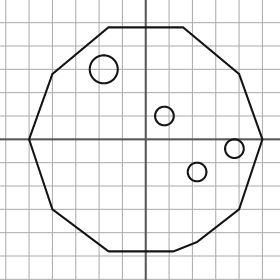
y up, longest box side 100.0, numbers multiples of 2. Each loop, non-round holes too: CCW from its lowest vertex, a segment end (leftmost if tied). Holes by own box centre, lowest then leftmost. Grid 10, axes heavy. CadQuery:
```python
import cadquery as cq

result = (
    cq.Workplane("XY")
    .moveTo(-16.0, -48.0)
    .lineTo(12.0, -48.0)
    .lineTo(22.0, -44.0)
    .lineTo(40.0, -30.0)
    .lineTo(50.0, 0.0)
    .lineTo(40.0, 28.0)
    .lineTo(16.0, 48.0)
    .lineTo(-16.0, 48.0)
    .lineTo(-40.0, 28.0)
    .lineTo(-50.0, 0.0)
    .lineTo(-40.0, -30.0)
    .close()
    .moveTo(22.0, -14.0)
    .circle(4.0)
    .moveTo(38.0, -4.0)
    .circle(4.0)
    .moveTo(8.0, 10.0)
    .circle(4.0)
    .moveTo(-18.0, 30.0)
    .circle(6.0)
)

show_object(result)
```